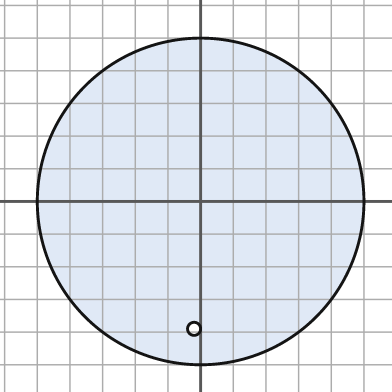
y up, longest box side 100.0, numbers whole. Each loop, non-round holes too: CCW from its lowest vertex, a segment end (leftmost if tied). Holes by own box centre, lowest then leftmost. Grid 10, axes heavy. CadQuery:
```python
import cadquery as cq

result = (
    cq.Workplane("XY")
    .moveTo(0.0, 0.0)
    .circle(50.0)
    .moveTo(-2.0, -39.0)
    .circle(2.0)
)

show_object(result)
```